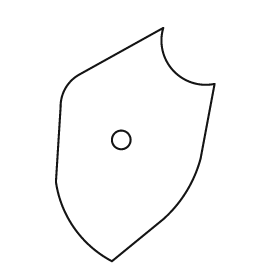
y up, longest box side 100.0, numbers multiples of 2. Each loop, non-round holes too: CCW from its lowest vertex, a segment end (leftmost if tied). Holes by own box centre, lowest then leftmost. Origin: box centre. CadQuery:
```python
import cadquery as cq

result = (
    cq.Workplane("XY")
    .moveTo(-10.0, -50.0)
    .lineTo(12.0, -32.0)
    .threePointArc((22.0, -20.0), (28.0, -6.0))
    .lineTo(34.0, 26.0)
    .threePointArc((16.0, 32.0), (12.0, 50.0))
    .lineTo(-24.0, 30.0)
    .threePointArc((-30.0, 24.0), (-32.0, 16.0))
    .lineTo(-34.0, -16.0)
    .threePointArc((-26.0, -36.0), (-10.0, -50.0))
    .close()
    .moveTo(-6.0, 2.0)
    .circle(4.0)
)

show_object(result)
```